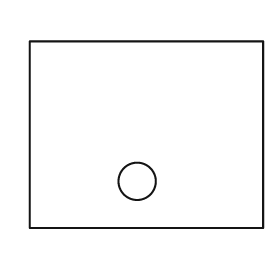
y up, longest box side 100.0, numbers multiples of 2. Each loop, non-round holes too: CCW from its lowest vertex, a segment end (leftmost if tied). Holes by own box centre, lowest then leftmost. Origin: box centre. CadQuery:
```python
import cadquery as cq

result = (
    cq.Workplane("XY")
    .moveTo(-50.0, -40.0)
    .lineTo(50.0, -40.0)
    .lineTo(50.0, 40.0)
    .lineTo(-50.0, 40.0)
    .close()
    .moveTo(-4.0, -20.0)
    .circle(8.0)
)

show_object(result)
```